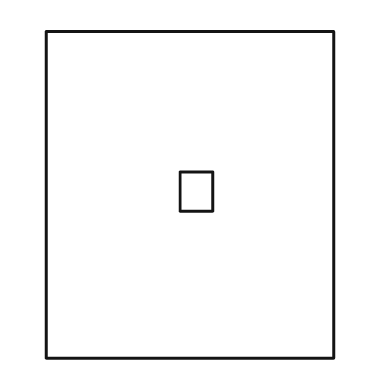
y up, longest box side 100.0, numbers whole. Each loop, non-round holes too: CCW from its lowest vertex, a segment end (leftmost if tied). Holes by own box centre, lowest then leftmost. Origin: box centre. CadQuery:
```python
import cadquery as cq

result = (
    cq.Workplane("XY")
    .moveTo(-44.0, -50.0)
    .lineTo(44.0, -50.0)
    .lineTo(44.0, 50.0)
    .lineTo(-44.0, 50.0)
    .close()
    .moveTo(-3.0, -5.0)
    .lineTo(7.0, -5.0)
    .lineTo(7.0, 7.0)
    .lineTo(-3.0, 7.0)
    .close()
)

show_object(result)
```